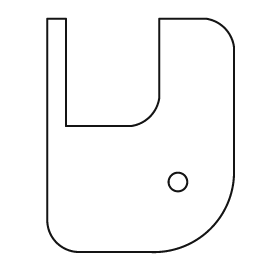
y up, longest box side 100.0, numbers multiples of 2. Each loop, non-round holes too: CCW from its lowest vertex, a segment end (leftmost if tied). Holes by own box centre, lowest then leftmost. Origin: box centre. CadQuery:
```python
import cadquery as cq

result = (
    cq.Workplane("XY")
    .moveTo(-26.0, -50.0)
    .lineTo(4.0, -50.0)
    .threePointArc((30.0, -40.0), (40.0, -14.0))
    .lineTo(40.0, 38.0)
    .threePointArc((36.0, 46.0), (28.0, 50.0))
    .lineTo(8.0, 50.0)
    .lineTo(8.0, 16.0)
    .threePointArc((4.0, 8.0), (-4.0, 4.0))
    .lineTo(-32.0, 4.0)
    .lineTo(-32.0, 50.0)
    .lineTo(-40.0, 50.0)
    .lineTo(-40.0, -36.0)
    .threePointArc((-36.0, -46.0), (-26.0, -50.0))
    .close()
    .moveTo(16.0, -20.0)
    .circle(4.0)
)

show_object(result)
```